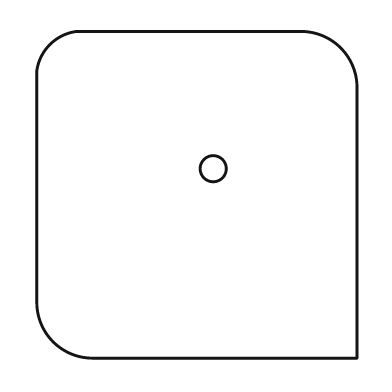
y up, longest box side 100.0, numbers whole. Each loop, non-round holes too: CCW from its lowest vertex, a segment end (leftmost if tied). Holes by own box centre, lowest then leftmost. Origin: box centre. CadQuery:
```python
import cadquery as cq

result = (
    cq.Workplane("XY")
    .moveTo(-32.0, -50.0)
    .lineTo(49.0, -50.0)
    .lineTo(49.0, 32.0)
    .threePointArc((44.0, 45.0), (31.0, 50.0))
    .lineTo(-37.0, 50.0)
    .threePointArc((-45.0, 46.0), (-49.0, 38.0))
    .lineTo(-49.0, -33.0)
    .threePointArc((-44.0, -45.0), (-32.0, -50.0))
    .close()
    .moveTo(5.0, 8.0)
    .circle(4.0)
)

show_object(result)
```